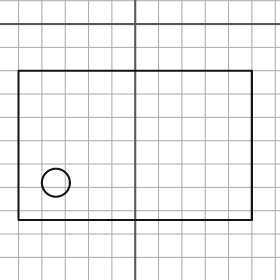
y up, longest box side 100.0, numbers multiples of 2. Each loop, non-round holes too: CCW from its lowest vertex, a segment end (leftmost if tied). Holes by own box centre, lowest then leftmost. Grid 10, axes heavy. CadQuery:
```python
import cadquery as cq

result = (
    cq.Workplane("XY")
    .moveTo(-50.0, -84.0)
    .lineTo(50.0, -84.0)
    .lineTo(50.0, -20.0)
    .lineTo(-50.0, -20.0)
    .close()
    .moveTo(-34.0, -68.0)
    .circle(6.0)
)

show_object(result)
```